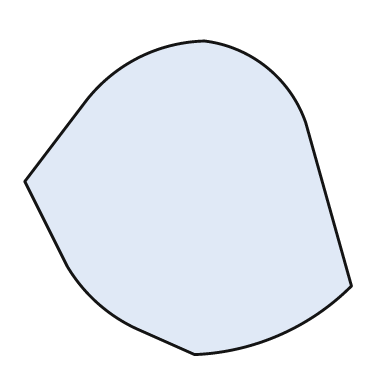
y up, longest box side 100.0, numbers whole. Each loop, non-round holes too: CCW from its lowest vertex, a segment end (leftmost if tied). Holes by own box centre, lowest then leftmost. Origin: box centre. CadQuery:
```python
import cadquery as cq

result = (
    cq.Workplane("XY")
    .moveTo(2.0, -48.0)
    .threePointArc((28.0, -42.0), (50.0, -27.0))
    .lineTo(36.0, 23.0)
    .threePointArc((24.0, 40.0), (5.0, 48.0))
    .threePointArc((-15.0, 43.0), (-31.0, 30.0))
    .lineTo(-50.0, 5.0)
    .lineTo(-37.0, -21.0)
    .threePointArc((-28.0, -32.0), (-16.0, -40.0))
    .close()
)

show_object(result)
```